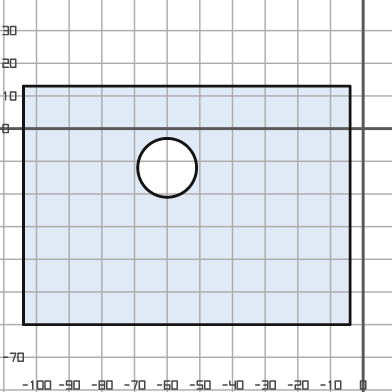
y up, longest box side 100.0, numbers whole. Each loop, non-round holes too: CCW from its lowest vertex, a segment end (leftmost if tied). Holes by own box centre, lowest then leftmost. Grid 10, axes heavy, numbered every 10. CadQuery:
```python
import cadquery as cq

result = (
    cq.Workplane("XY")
    .moveTo(-104.0, -60.0)
    .lineTo(-4.0, -60.0)
    .lineTo(-4.0, 13.0)
    .lineTo(-104.0, 13.0)
    .close()
    .moveTo(-60.0, -12.0)
    .circle(9.0)
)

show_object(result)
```